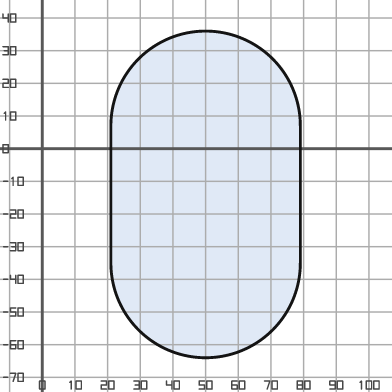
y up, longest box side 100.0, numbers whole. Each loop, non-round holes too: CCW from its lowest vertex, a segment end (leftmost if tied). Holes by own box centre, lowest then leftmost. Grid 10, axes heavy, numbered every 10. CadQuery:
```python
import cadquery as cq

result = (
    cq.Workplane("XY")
    .moveTo(21.0, -35.0)
    .threePointArc((50.0, -64.0), (79.0, -35.0))
    .lineTo(79.0, 7.0)
    .threePointArc((50.0, 36.0), (21.0, 7.0))
    .close()
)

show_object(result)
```